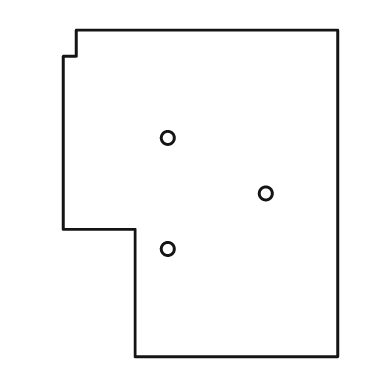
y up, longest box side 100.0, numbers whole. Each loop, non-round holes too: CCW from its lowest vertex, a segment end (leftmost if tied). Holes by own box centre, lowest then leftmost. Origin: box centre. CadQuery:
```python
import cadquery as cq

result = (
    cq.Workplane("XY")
    .moveTo(-20.0, -50.0)
    .lineTo(42.0, -50.0)
    .lineTo(42.0, 50.0)
    .lineTo(-38.0, 50.0)
    .lineTo(-38.0, 42.0)
    .lineTo(-42.0, 42.0)
    .lineTo(-42.0, -11.0)
    .lineTo(-20.0, -11.0)
    .close()
    .moveTo(-10.0, -17.0)
    .circle(2.0)
    .moveTo(20.0, 0.0)
    .circle(2.0)
    .moveTo(-10.0, 17.0)
    .circle(2.0)
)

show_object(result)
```